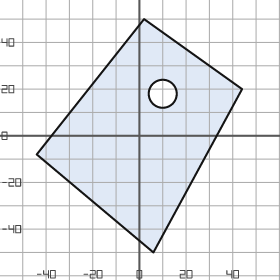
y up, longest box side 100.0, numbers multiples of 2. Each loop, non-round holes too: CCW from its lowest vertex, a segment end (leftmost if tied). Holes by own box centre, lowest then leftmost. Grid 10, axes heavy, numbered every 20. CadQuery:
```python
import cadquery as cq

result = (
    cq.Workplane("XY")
    .moveTo(6.0, -50.0)
    .lineTo(44.0, 20.0)
    .lineTo(2.0, 50.0)
    .lineTo(-44.0, -8.0)
    .close()
    .moveTo(10.0, 18.0)
    .circle(6.0)
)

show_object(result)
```